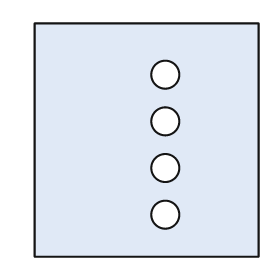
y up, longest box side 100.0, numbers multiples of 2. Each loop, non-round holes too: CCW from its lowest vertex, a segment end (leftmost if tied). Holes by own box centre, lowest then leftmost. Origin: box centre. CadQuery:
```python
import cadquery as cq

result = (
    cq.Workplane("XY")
    .moveTo(-48.0, -50.0)
    .lineTo(48.0, -50.0)
    .lineTo(48.0, 50.0)
    .lineTo(-48.0, 50.0)
    .close()
    .moveTo(8.0, -32.0)
    .circle(6.0)
    .moveTo(8.0, -12.0)
    .circle(6.0)
    .moveTo(8.0, 8.0)
    .circle(6.0)
    .moveTo(8.0, 28.0)
    .circle(6.0)
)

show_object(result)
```